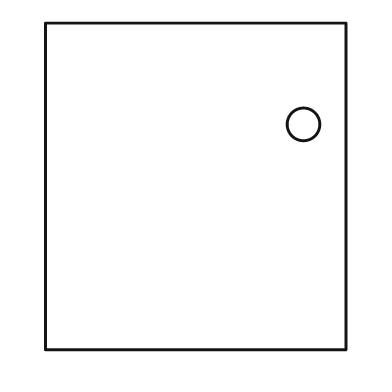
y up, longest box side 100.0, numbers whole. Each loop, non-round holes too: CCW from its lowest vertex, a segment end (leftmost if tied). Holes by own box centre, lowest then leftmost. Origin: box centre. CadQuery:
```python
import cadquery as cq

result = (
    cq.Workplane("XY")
    .moveTo(-46.0, -50.0)
    .lineTo(46.0, -50.0)
    .lineTo(46.0, 50.0)
    .lineTo(-46.0, 50.0)
    .close()
    .moveTo(33.0, 19.0)
    .circle(5.0)
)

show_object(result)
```